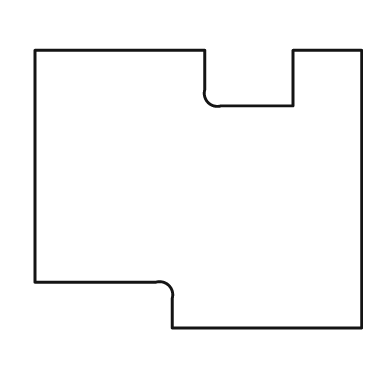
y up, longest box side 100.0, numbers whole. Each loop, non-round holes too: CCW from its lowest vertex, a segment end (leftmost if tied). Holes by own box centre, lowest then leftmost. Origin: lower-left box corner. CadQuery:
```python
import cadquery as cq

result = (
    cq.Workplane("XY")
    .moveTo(42.0, 0.0)
    .lineTo(100.0, 0.0)
    .lineTo(100.0, 85.0)
    .lineTo(79.0, 85.0)
    .lineTo(79.0, 68.0)
    .lineTo(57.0, 68.0)
    .threePointArc((53.0, 69.0), (52.0, 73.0))
    .lineTo(52.0, 85.0)
    .lineTo(0.0, 85.0)
    .lineTo(0.0, 14.0)
    .lineTo(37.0, 14.0)
    .threePointArc((41.0, 13.0), (42.0, 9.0))
    .close()
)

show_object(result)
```